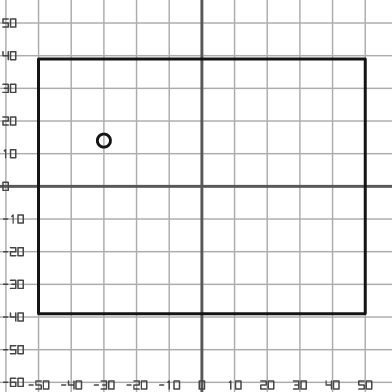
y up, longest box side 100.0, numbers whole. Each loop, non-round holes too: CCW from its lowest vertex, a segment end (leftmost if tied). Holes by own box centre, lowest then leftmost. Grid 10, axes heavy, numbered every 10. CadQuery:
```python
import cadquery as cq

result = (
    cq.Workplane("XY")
    .moveTo(-50.0, -39.0)
    .lineTo(50.0, -39.0)
    .lineTo(50.0, 39.0)
    .lineTo(-50.0, 39.0)
    .close()
    .moveTo(-30.0, 14.0)
    .circle(2.0)
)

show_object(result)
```